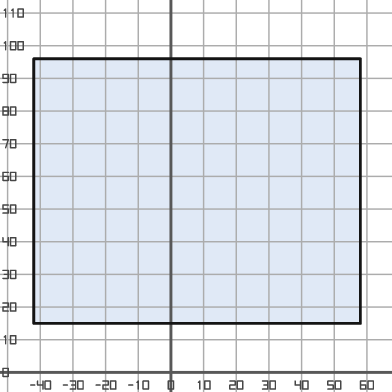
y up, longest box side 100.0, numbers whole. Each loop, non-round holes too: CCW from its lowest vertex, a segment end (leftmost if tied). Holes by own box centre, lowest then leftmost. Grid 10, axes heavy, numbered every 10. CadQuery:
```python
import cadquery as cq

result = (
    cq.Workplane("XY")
    .moveTo(-42.0, 15.0)
    .lineTo(58.0, 15.0)
    .lineTo(58.0, 96.0)
    .lineTo(-42.0, 96.0)
    .close()
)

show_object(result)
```